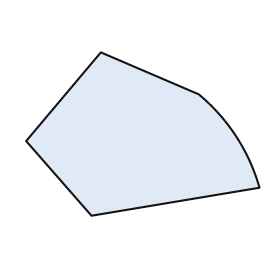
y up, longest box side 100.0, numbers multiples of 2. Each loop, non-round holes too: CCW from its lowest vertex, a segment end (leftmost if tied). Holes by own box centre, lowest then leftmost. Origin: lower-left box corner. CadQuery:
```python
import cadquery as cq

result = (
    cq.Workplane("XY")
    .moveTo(28.0, 0.0)
    .lineTo(100.0, 12.0)
    .threePointArc((90.0, 34.0), (74.0, 52.0))
    .lineTo(32.0, 70.0)
    .lineTo(0.0, 32.0)
    .close()
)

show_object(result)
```